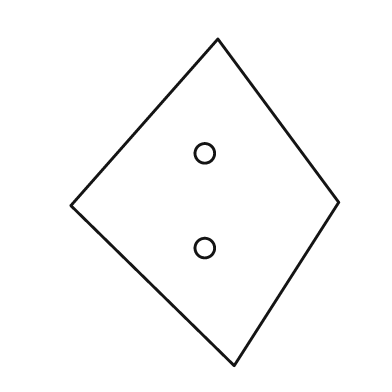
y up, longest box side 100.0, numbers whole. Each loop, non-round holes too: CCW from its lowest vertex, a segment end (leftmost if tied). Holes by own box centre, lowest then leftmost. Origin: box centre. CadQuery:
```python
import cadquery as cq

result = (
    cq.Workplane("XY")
    .moveTo(9.0, -50.0)
    .lineTo(41.0, 0.0)
    .lineTo(4.0, 50.0)
    .lineTo(-41.0, -1.0)
    .close()
    .moveTo(0.0, -14.0)
    .circle(3.0)
    .moveTo(0.0, 15.0)
    .circle(3.0)
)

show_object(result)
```